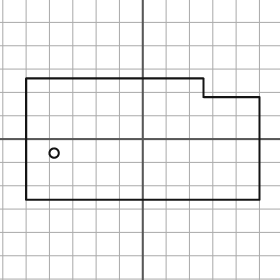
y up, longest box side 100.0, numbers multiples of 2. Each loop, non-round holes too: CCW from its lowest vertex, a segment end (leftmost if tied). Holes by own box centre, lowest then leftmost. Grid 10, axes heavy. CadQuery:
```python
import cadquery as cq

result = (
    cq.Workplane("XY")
    .moveTo(-50.0, -26.0)
    .lineTo(50.0, -26.0)
    .lineTo(50.0, 18.0)
    .lineTo(26.0, 18.0)
    .lineTo(26.0, 26.0)
    .lineTo(-50.0, 26.0)
    .close()
    .moveTo(-38.0, -6.0)
    .circle(2.0)
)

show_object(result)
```